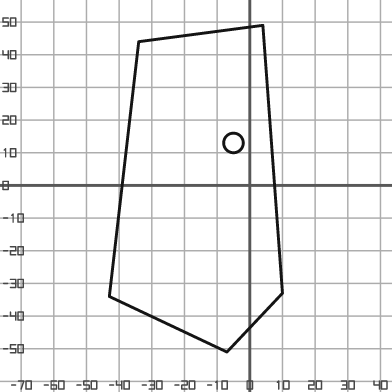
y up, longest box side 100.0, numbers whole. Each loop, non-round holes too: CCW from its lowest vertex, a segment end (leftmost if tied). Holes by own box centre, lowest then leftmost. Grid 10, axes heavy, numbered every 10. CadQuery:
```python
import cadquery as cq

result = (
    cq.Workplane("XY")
    .moveTo(-7.0, -51.0)
    .lineTo(10.0, -33.0)
    .lineTo(4.0, 49.0)
    .lineTo(-34.0, 44.0)
    .lineTo(-43.0, -34.0)
    .close()
    .moveTo(-5.0, 13.0)
    .circle(3.0)
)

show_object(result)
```